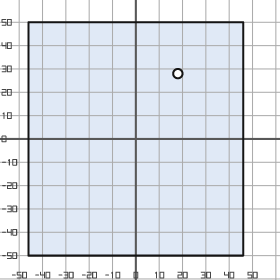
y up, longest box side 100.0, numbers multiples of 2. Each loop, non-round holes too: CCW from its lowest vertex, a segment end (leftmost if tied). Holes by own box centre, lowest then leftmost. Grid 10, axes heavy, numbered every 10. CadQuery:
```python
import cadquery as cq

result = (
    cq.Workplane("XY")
    .moveTo(-46.0, -50.0)
    .lineTo(46.0, -50.0)
    .lineTo(46.0, 50.0)
    .lineTo(-46.0, 50.0)
    .close()
    .moveTo(18.0, 28.0)
    .circle(2.0)
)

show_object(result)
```